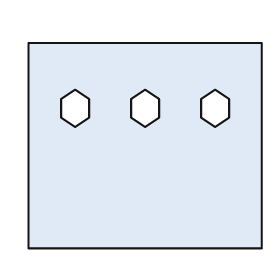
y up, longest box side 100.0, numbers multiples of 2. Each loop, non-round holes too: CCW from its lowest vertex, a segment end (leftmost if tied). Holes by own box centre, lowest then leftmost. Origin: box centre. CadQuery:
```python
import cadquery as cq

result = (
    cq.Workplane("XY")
    .moveTo(-50.0, -44.0)
    .lineTo(50.0, -44.0)
    .lineTo(50.0, 44.0)
    .lineTo(-50.0, 44.0)
    .close()
    .moveTo(-30.0, 8.0)
    .lineTo(-24.0, 12.0)
    .lineTo(-24.0, 20.0)
    .lineTo(-30.0, 24.0)
    .lineTo(-36.0, 20.0)
    .lineTo(-36.0, 12.0)
    .close()
    .moveTo(0.0, 8.0)
    .lineTo(6.0, 12.0)
    .lineTo(6.0, 20.0)
    .lineTo(0.0, 24.0)
    .lineTo(-6.0, 20.0)
    .lineTo(-6.0, 12.0)
    .close()
    .moveTo(30.0, 8.0)
    .lineTo(36.0, 12.0)
    .lineTo(36.0, 20.0)
    .lineTo(30.0, 24.0)
    .lineTo(24.0, 20.0)
    .lineTo(24.0, 12.0)
    .close()
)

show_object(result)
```